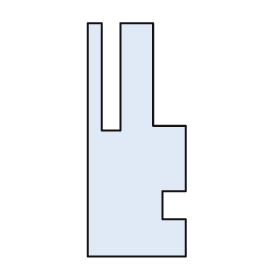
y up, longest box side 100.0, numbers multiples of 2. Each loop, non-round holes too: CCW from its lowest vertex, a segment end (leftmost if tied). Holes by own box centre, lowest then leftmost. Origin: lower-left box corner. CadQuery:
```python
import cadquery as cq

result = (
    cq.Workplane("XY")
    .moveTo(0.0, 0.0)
    .lineTo(42.0, 0.0)
    .lineTo(42.0, 16.0)
    .lineTo(32.0, 16.0)
    .lineTo(32.0, 28.0)
    .lineTo(42.0, 28.0)
    .lineTo(42.0, 56.0)
    .lineTo(28.0, 56.0)
    .lineTo(28.0, 100.0)
    .lineTo(14.0, 100.0)
    .lineTo(14.0, 54.0)
    .lineTo(6.0, 54.0)
    .lineTo(6.0, 100.0)
    .lineTo(0.0, 100.0)
    .close()
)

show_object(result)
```